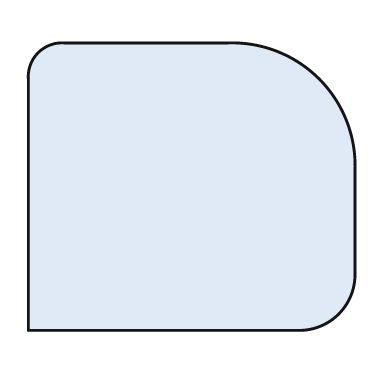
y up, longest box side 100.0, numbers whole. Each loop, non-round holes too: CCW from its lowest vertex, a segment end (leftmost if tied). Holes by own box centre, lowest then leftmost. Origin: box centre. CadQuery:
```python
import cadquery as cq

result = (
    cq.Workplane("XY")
    .moveTo(-50.0, -44.0)
    .lineTo(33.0, -44.0)
    .threePointArc((45.0, -39.0), (50.0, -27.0))
    .lineTo(50.0, 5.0)
    .threePointArc((39.0, 33.0), (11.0, 44.0))
    .lineTo(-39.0, 44.0)
    .threePointArc((-47.0, 41.0), (-50.0, 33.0))
    .close()
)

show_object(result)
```